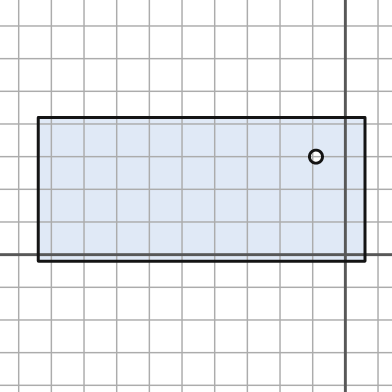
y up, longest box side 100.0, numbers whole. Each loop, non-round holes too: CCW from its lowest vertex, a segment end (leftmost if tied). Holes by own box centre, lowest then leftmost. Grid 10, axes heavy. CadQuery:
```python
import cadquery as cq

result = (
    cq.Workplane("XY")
    .moveTo(-94.0, -2.0)
    .lineTo(6.0, -2.0)
    .lineTo(6.0, 42.0)
    .lineTo(-94.0, 42.0)
    .close()
    .moveTo(-9.0, 30.0)
    .circle(2.0)
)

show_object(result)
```